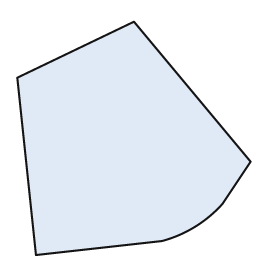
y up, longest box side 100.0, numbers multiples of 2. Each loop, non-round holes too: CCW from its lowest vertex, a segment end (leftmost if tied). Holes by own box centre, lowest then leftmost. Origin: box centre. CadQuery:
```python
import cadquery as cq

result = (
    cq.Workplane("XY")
    .moveTo(-42.0, -50.0)
    .lineTo(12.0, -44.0)
    .threePointArc((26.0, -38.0), (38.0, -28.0))
    .lineTo(50.0, -10.0)
    .lineTo(0.0, 50.0)
    .lineTo(-50.0, 26.0)
    .close()
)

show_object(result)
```